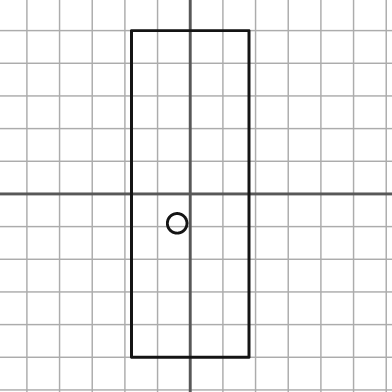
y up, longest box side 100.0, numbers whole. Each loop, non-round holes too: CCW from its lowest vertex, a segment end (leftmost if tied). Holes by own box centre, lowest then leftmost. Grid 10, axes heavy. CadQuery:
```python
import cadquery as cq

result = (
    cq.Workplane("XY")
    .moveTo(-18.0, -50.0)
    .lineTo(18.0, -50.0)
    .lineTo(18.0, 50.0)
    .lineTo(-18.0, 50.0)
    .close()
    .moveTo(-4.0, -9.0)
    .circle(3.0)
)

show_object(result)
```